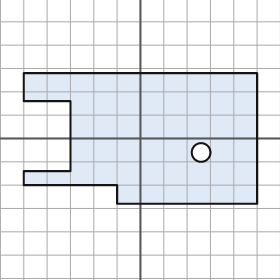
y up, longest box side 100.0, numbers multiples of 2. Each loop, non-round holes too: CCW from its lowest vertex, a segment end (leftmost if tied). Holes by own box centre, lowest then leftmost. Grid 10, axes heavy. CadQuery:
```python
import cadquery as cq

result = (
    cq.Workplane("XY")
    .moveTo(-10.0, -28.0)
    .lineTo(50.0, -28.0)
    .lineTo(50.0, 28.0)
    .lineTo(-50.0, 28.0)
    .lineTo(-50.0, 16.0)
    .lineTo(-30.0, 16.0)
    .lineTo(-30.0, -14.0)
    .lineTo(-50.0, -14.0)
    .lineTo(-50.0, -20.0)
    .lineTo(-10.0, -20.0)
    .close()
    .moveTo(26.0, -6.0)
    .circle(4.0)
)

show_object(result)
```